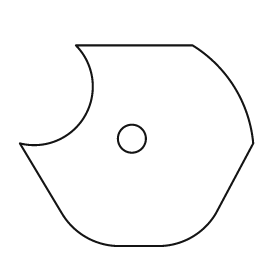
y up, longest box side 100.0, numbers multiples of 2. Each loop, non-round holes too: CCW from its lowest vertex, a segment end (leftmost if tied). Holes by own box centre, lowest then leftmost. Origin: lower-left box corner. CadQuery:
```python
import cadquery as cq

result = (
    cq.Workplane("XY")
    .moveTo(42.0, 0.0)
    .lineTo(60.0, 0.0)
    .threePointArc((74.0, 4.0), (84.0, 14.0))
    .lineTo(100.0, 44.0)
    .threePointArc((92.0, 68.0), (74.0, 86.0))
    .lineTo(24.0, 86.0)
    .threePointArc((28.0, 56.0), (0.0, 44.0))
    .lineTo(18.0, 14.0)
    .threePointArc((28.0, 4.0), (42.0, 0.0))
    .close()
    .moveTo(48.0, 46.0)
    .circle(6.0)
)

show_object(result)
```